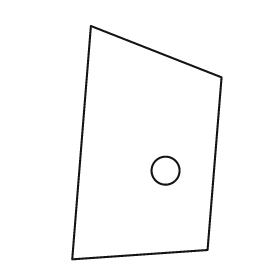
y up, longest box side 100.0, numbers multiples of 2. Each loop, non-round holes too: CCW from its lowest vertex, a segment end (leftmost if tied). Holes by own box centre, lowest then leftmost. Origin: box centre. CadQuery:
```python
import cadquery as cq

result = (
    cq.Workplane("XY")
    .moveTo(-32.0, -50.0)
    .lineTo(26.0, -46.0)
    .lineTo(32.0, 28.0)
    .lineTo(-24.0, 50.0)
    .close()
    .moveTo(8.0, -12.0)
    .circle(6.0)
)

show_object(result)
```